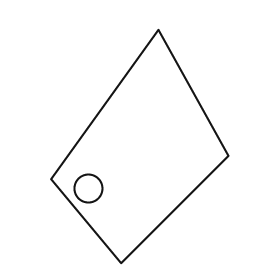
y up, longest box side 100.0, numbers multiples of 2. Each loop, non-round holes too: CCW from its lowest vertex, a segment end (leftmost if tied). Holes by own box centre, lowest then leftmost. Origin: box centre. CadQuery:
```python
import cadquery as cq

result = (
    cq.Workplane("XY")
    .moveTo(-8.0, -50.0)
    .lineTo(38.0, -4.0)
    .lineTo(8.0, 50.0)
    .lineTo(-38.0, -14.0)
    .close()
    .moveTo(-22.0, -18.0)
    .circle(6.0)
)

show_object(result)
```